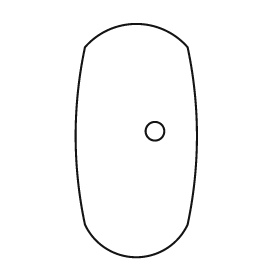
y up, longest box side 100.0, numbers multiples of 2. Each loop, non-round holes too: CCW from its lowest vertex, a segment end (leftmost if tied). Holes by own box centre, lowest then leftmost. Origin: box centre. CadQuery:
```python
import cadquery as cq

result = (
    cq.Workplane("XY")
    .moveTo(-22.0, -36.0)
    .threePointArc((0.0, -50.0), (22.0, -36.0))
    .threePointArc((26.0, 2.0), (22.0, 40.0))
    .threePointArc((0.0, 50.0), (-22.0, 40.0))
    .threePointArc((-26.0, 2.0), (-22.0, -36.0))
    .close()
    .moveTo(8.0, 4.0)
    .circle(4.0)
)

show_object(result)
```